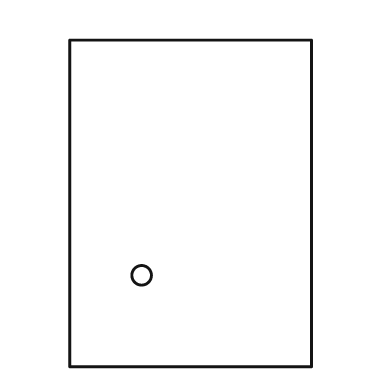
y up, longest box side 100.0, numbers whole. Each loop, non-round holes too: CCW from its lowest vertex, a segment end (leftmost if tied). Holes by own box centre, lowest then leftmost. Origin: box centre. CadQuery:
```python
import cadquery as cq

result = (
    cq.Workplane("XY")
    .moveTo(-37.0, -50.0)
    .lineTo(37.0, -50.0)
    .lineTo(37.0, 50.0)
    .lineTo(-37.0, 50.0)
    .close()
    .moveTo(-15.0, -22.0)
    .circle(3.0)
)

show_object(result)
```